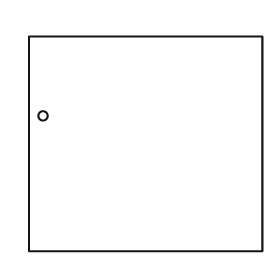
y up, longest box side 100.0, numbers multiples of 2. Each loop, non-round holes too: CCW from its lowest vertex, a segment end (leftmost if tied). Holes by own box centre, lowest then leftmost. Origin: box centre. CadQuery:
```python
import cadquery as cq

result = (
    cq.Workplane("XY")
    .moveTo(-50.0, -46.0)
    .lineTo(50.0, -46.0)
    .lineTo(50.0, 46.0)
    .lineTo(-50.0, 46.0)
    .close()
    .moveTo(-44.0, 12.0)
    .circle(2.0)
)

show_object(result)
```